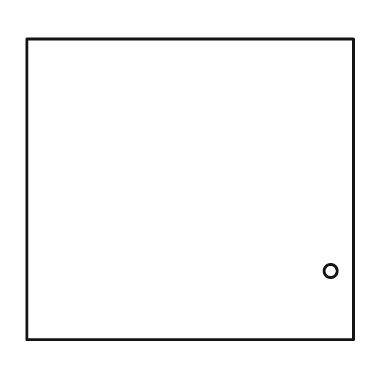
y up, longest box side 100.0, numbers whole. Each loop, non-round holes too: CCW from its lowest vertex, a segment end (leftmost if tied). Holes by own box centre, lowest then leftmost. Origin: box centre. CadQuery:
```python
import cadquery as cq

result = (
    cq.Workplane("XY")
    .moveTo(-50.0, -46.0)
    .lineTo(50.0, -46.0)
    .lineTo(50.0, 46.0)
    .lineTo(-50.0, 46.0)
    .close()
    .moveTo(43.0, -25.0)
    .circle(2.0)
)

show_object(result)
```